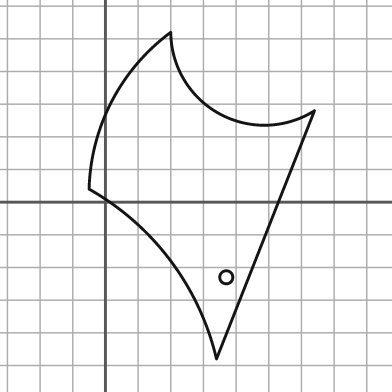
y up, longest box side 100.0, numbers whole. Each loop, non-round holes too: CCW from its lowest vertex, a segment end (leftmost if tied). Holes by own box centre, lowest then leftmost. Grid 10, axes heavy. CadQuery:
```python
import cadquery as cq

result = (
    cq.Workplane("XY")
    .moveTo(34.0, -48.0)
    .lineTo(64.0, 28.0)
    .threePointArc((35.0, 27.0), (20.0, 52.0))
    .threePointArc((2.0, 31.0), (-5.0, 4.0))
    .threePointArc((20.0, -18.0), (34.0, -48.0))
    .close()
    .moveTo(37.0, -23.0)
    .circle(2.0)
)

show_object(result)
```